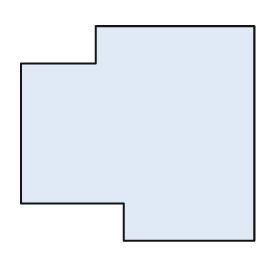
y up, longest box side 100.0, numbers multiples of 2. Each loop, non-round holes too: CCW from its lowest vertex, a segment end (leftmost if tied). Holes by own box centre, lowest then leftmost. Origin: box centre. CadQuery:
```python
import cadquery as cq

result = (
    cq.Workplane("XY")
    .moveTo(-6.0, -46.0)
    .lineTo(50.0, -46.0)
    .lineTo(50.0, 46.0)
    .lineTo(-18.0, 46.0)
    .lineTo(-18.0, 30.0)
    .lineTo(-50.0, 30.0)
    .lineTo(-50.0, -30.0)
    .lineTo(-6.0, -30.0)
    .close()
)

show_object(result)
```